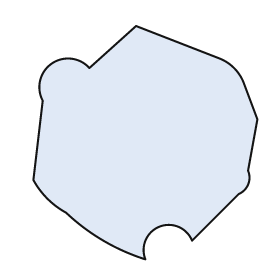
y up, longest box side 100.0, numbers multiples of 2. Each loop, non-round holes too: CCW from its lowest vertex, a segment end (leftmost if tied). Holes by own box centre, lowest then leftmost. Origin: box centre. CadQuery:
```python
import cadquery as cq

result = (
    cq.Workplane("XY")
    .moveTo(0.0, -50.0)
    .threePointArc((6.0, -36.0), (20.0, -42.0))
    .lineTo(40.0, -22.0)
    .threePointArc((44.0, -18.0), (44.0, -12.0))
    .lineTo(48.0, 10.0)
    .lineTo(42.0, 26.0)
    .threePointArc((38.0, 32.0), (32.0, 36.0))
    .lineTo(-4.0, 50.0)
    .lineTo(-24.0, 32.0)
    .threePointArc((-40.0, 34.0), (-44.0, 18.0))
    .lineTo(-48.0, -16.0)
    .threePointArc((-42.0, -24.0), (-34.0, -30.0))
    .threePointArc((-18.0, -42.0), (0.0, -50.0))
    .close()
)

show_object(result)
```